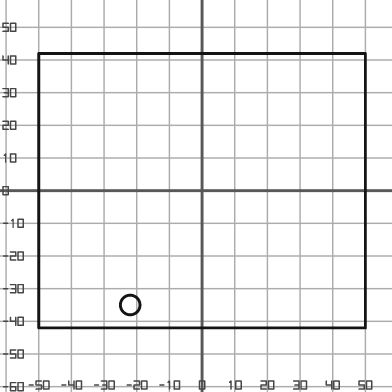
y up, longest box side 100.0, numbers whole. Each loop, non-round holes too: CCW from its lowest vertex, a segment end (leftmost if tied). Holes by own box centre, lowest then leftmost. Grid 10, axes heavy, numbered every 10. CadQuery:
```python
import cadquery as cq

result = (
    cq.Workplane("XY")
    .moveTo(-50.0, -42.0)
    .lineTo(50.0, -42.0)
    .lineTo(50.0, 42.0)
    .lineTo(-50.0, 42.0)
    .close()
    .moveTo(-22.0, -35.0)
    .circle(3.0)
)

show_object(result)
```